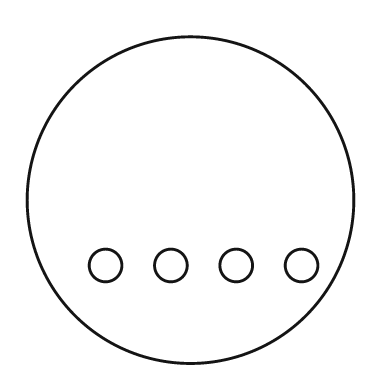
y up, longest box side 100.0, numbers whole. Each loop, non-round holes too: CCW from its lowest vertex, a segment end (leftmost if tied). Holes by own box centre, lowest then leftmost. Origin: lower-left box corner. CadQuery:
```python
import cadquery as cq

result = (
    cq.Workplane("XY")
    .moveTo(50.0, 50.0)
    .circle(50.0)
    .moveTo(24.0, 30.0)
    .circle(5.0)
    .moveTo(44.0, 30.0)
    .circle(5.0)
    .moveTo(64.0, 30.0)
    .circle(5.0)
    .moveTo(84.0, 30.0)
    .circle(5.0)
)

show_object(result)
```